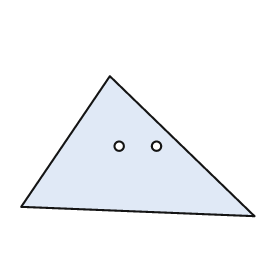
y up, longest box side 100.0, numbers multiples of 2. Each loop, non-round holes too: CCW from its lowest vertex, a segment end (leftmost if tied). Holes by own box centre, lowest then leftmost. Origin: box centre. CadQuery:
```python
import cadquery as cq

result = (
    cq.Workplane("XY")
    .moveTo(50.0, -30.0)
    .lineTo(-12.0, 30.0)
    .lineTo(-50.0, -26.0)
    .close()
    .moveTo(-8.0, 0.0)
    .circle(2.0)
    .moveTo(8.0, 0.0)
    .circle(2.0)
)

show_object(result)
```